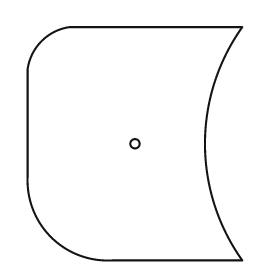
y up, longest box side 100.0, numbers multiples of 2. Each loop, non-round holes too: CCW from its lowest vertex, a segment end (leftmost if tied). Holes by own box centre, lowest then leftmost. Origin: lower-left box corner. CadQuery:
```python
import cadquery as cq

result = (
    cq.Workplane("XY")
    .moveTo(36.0, 0.0)
    .lineTo(92.0, 0.0)
    .threePointArc((76.0, 50.0), (92.0, 100.0))
    .lineTo(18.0, 100.0)
    .threePointArc((6.0, 94.0), (0.0, 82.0))
    .lineTo(0.0, 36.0)
    .threePointArc((10.0, 10.0), (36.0, 0.0))
    .close()
    .moveTo(46.0, 50.0)
    .circle(2.0)
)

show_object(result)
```